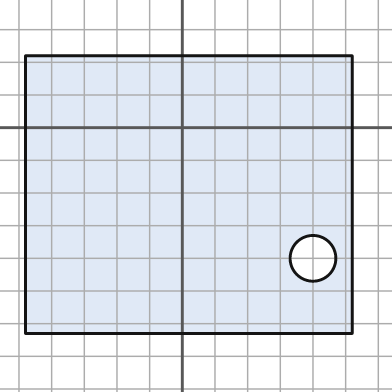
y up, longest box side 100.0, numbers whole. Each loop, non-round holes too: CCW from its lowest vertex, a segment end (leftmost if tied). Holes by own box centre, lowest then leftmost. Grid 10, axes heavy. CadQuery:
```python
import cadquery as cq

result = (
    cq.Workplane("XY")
    .moveTo(-48.0, -63.0)
    .lineTo(52.0, -63.0)
    .lineTo(52.0, 22.0)
    .lineTo(-48.0, 22.0)
    .close()
    .moveTo(40.0, -40.0)
    .circle(7.0)
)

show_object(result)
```